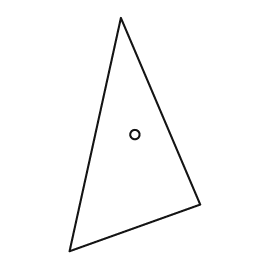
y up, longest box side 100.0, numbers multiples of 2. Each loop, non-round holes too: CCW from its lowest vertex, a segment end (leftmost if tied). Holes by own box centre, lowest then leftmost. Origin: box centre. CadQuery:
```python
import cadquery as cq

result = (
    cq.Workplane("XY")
    .moveTo(-28.0, -50.0)
    .lineTo(28.0, -30.0)
    .lineTo(-6.0, 50.0)
    .close()
    .moveTo(0.0, 0.0)
    .circle(2.0)
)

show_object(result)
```